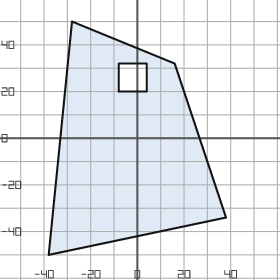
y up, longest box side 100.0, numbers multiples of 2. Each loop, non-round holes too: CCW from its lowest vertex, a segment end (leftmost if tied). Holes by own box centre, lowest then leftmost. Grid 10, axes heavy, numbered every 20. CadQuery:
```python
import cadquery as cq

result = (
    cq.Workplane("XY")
    .moveTo(-38.0, -50.0)
    .lineTo(38.0, -34.0)
    .lineTo(16.0, 32.0)
    .lineTo(-28.0, 50.0)
    .close()
    .moveTo(-8.0, 20.0)
    .lineTo(4.0, 20.0)
    .lineTo(4.0, 32.0)
    .lineTo(-8.0, 32.0)
    .close()
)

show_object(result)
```